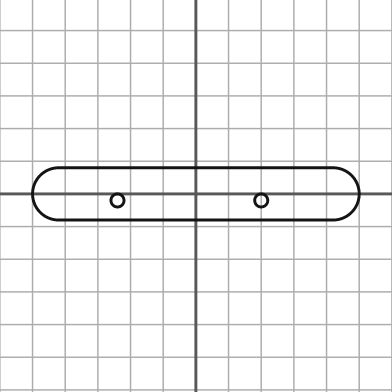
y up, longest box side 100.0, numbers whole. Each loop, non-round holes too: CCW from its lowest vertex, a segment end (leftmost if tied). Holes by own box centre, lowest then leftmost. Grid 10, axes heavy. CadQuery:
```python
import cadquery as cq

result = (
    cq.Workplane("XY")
    .moveTo(-42.0, -8.0)
    .lineTo(42.0, -8.0)
    .threePointArc((50.0, 0.0), (42.0, 8.0))
    .lineTo(-42.0, 8.0)
    .threePointArc((-50.0, 0.0), (-42.0, -8.0))
    .close()
    .moveTo(-24.0, -2.0)
    .circle(2.0)
    .moveTo(20.0, -2.0)
    .circle(2.0)
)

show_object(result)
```